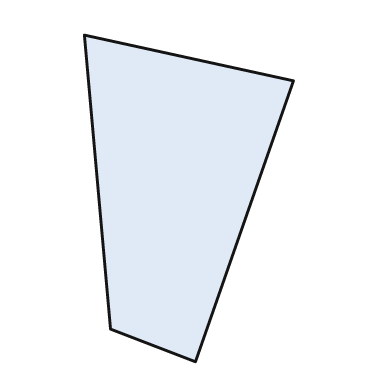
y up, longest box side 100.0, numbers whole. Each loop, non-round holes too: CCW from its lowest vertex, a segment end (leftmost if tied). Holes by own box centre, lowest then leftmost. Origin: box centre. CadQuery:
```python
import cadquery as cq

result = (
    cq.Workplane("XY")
    .moveTo(2.0, -50.0)
    .lineTo(32.0, 36.0)
    .lineTo(-32.0, 50.0)
    .lineTo(-24.0, -40.0)
    .close()
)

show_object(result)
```